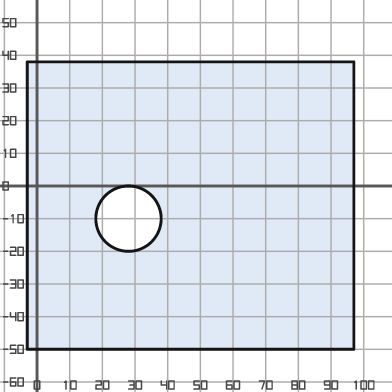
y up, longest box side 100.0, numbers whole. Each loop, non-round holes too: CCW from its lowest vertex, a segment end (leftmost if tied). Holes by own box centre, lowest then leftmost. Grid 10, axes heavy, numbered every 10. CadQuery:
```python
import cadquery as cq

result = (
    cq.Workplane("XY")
    .moveTo(-3.0, -50.0)
    .lineTo(97.0, -50.0)
    .lineTo(97.0, 38.0)
    .lineTo(-3.0, 38.0)
    .close()
    .moveTo(28.0, -10.0)
    .circle(10.0)
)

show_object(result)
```